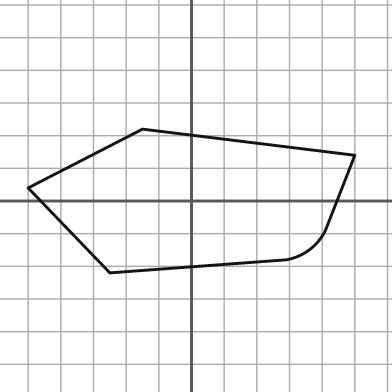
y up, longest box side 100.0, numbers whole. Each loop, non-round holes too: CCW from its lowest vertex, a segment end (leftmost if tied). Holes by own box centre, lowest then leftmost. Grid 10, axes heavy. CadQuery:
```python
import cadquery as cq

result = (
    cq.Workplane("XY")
    .moveTo(-25.0, -22.0)
    .lineTo(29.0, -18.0)
    .threePointArc((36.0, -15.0), (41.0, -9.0))
    .lineTo(50.0, 14.0)
    .lineTo(-15.0, 22.0)
    .lineTo(-50.0, 4.0)
    .close()
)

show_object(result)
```